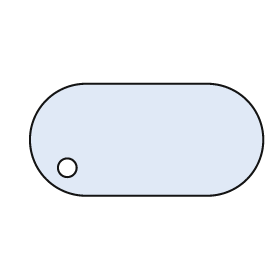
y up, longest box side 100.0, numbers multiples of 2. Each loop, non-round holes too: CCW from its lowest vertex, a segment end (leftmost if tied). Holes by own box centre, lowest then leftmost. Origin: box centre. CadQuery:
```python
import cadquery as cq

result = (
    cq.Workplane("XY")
    .moveTo(-26.0, -24.0)
    .lineTo(26.0, -24.0)
    .threePointArc((50.0, 0.0), (26.0, 24.0))
    .lineTo(-26.0, 24.0)
    .threePointArc((-50.0, 0.0), (-26.0, -24.0))
    .close()
    .moveTo(-34.0, -12.0)
    .circle(4.0)
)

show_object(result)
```